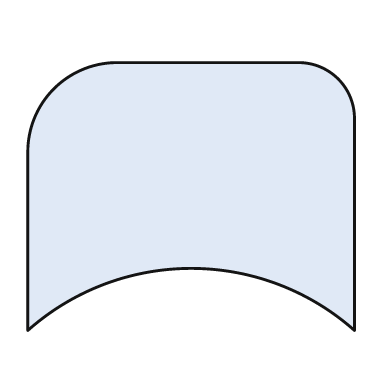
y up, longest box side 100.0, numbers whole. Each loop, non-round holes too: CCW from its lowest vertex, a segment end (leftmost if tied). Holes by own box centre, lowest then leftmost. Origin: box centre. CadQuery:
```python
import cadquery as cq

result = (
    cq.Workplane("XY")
    .moveTo(-50.0, -41.0)
    .threePointArc((0.0, -22.0), (50.0, -41.0))
    .lineTo(50.0, 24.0)
    .threePointArc((45.0, 36.0), (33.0, 41.0))
    .lineTo(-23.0, 41.0)
    .threePointArc((-42.0, 33.0), (-50.0, 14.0))
    .close()
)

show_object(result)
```